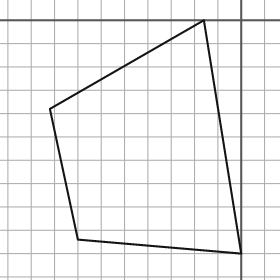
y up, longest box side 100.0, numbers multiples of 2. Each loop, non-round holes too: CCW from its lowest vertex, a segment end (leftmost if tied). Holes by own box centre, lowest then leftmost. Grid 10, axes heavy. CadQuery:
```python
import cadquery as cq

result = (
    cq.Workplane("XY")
    .moveTo(0.0, -100.0)
    .lineTo(-16.0, 0.0)
    .lineTo(-82.0, -38.0)
    .lineTo(-70.0, -94.0)
    .close()
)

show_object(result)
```